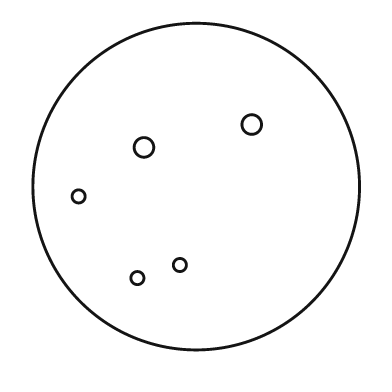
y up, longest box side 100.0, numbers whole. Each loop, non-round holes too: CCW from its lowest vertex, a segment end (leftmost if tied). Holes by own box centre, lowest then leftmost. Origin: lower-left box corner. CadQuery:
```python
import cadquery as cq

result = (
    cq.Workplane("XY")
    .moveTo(50.0, 50.0)
    .circle(50.0)
    .moveTo(32.0, 22.0)
    .circle(2.0)
    .moveTo(45.0, 26.0)
    .circle(2.0)
    .moveTo(14.0, 47.0)
    .circle(2.0)
    .moveTo(34.0, 62.0)
    .circle(3.0)
    .moveTo(67.0, 69.0)
    .circle(3.0)
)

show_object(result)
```